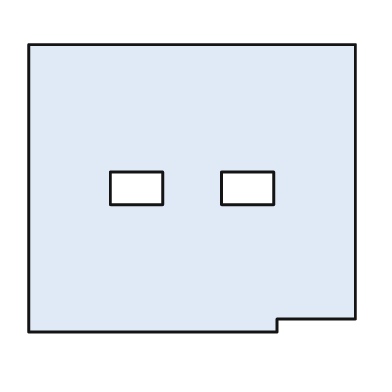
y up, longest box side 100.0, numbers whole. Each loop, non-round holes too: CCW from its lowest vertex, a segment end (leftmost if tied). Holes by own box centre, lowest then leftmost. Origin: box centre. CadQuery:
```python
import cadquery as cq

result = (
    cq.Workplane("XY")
    .moveTo(-50.0, -44.0)
    .lineTo(26.0, -44.0)
    .lineTo(26.0, -40.0)
    .lineTo(50.0, -40.0)
    .lineTo(50.0, 44.0)
    .lineTo(-50.0, 44.0)
    .close()
    .moveTo(-25.0, -5.0)
    .lineTo(-9.0, -5.0)
    .lineTo(-9.0, 5.0)
    .lineTo(-25.0, 5.0)
    .close()
    .moveTo(9.0, -5.0)
    .lineTo(25.0, -5.0)
    .lineTo(25.0, 5.0)
    .lineTo(9.0, 5.0)
    .close()
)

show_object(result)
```